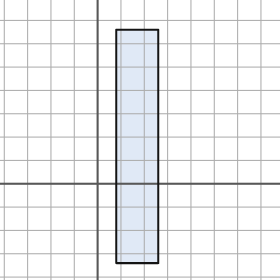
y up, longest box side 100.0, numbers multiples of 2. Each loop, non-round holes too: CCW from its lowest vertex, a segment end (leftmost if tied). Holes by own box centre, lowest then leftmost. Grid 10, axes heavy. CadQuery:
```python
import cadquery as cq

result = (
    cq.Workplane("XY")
    .moveTo(8.0, -34.0)
    .lineTo(26.0, -34.0)
    .lineTo(26.0, 66.0)
    .lineTo(8.0, 66.0)
    .close()
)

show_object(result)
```